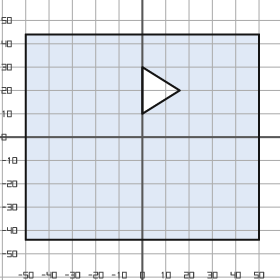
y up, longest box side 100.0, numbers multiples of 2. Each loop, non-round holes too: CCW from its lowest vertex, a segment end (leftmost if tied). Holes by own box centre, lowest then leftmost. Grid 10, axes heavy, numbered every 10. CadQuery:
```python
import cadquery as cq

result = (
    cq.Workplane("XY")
    .moveTo(-50.0, -44.0)
    .lineTo(50.0, -44.0)
    .lineTo(50.0, 44.0)
    .lineTo(-50.0, 44.0)
    .close()
    .moveTo(0.0, 10.0)
    .lineTo(16.0, 20.0)
    .lineTo(0.0, 30.0)
    .close()
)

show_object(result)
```